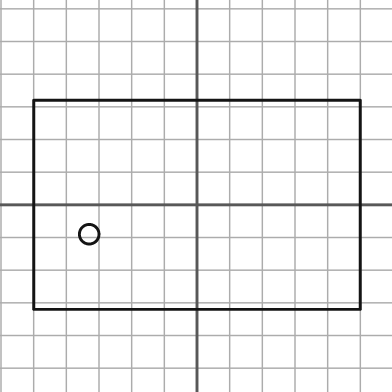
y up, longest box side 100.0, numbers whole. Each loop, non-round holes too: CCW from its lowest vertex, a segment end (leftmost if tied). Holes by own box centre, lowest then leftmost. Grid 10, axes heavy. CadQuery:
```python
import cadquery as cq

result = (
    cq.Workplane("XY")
    .moveTo(-50.0, -32.0)
    .lineTo(50.0, -32.0)
    .lineTo(50.0, 32.0)
    .lineTo(-50.0, 32.0)
    .close()
    .moveTo(-33.0, -9.0)
    .circle(3.0)
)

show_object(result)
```